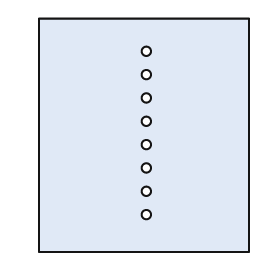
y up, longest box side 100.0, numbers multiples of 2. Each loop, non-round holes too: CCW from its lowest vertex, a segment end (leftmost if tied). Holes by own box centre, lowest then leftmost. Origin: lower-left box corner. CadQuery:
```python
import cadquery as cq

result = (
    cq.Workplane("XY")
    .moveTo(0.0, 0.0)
    .lineTo(90.0, 0.0)
    .lineTo(90.0, 100.0)
    .lineTo(0.0, 100.0)
    .close()
    .moveTo(46.0, 16.0)
    .circle(2.0)
    .moveTo(46.0, 26.0)
    .circle(2.0)
    .moveTo(46.0, 36.0)
    .circle(2.0)
    .moveTo(46.0, 46.0)
    .circle(2.0)
    .moveTo(46.0, 56.0)
    .circle(2.0)
    .moveTo(46.0, 66.0)
    .circle(2.0)
    .moveTo(46.0, 76.0)
    .circle(2.0)
    .moveTo(46.0, 86.0)
    .circle(2.0)
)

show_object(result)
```